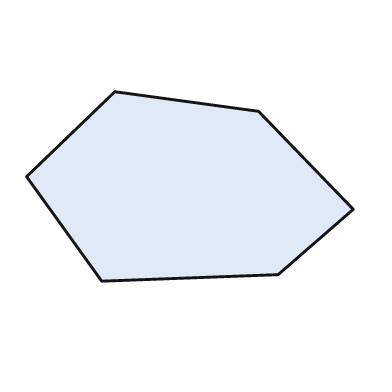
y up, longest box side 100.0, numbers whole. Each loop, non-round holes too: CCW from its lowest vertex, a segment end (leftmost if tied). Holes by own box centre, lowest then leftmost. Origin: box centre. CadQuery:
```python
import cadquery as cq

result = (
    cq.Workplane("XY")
    .moveTo(-27.0, -29.0)
    .lineTo(27.0, -27.0)
    .lineTo(50.0, -7.0)
    .lineTo(21.0, 23.0)
    .lineTo(-23.0, 29.0)
    .lineTo(-50.0, 3.0)
    .close()
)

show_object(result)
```